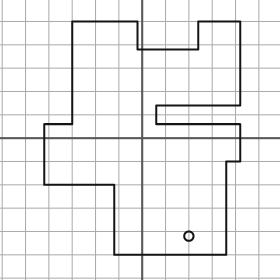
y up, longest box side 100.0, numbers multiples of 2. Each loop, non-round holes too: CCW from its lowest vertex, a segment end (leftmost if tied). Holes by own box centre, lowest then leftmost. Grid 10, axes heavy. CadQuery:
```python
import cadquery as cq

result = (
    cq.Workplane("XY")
    .moveTo(-12.0, -50.0)
    .lineTo(36.0, -50.0)
    .lineTo(36.0, -10.0)
    .lineTo(42.0, -10.0)
    .lineTo(42.0, 6.0)
    .lineTo(6.0, 6.0)
    .lineTo(6.0, 14.0)
    .lineTo(42.0, 14.0)
    .lineTo(42.0, 50.0)
    .lineTo(24.0, 50.0)
    .lineTo(24.0, 38.0)
    .lineTo(-2.0, 38.0)
    .lineTo(-2.0, 50.0)
    .lineTo(-30.0, 50.0)
    .lineTo(-30.0, 6.0)
    .lineTo(-42.0, 6.0)
    .lineTo(-42.0, -20.0)
    .lineTo(-12.0, -20.0)
    .close()
    .moveTo(20.0, -42.0)
    .circle(2.0)
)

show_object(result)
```